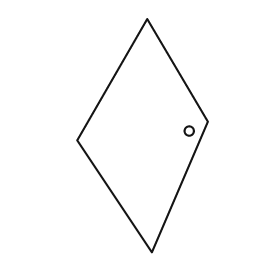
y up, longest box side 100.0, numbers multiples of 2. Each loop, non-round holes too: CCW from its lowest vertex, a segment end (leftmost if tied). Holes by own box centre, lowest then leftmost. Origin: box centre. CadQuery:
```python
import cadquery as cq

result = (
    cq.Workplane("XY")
    .moveTo(4.0, -50.0)
    .lineTo(28.0, 6.0)
    .lineTo(2.0, 50.0)
    .lineTo(-28.0, -2.0)
    .close()
    .moveTo(20.0, 2.0)
    .circle(2.0)
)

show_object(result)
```